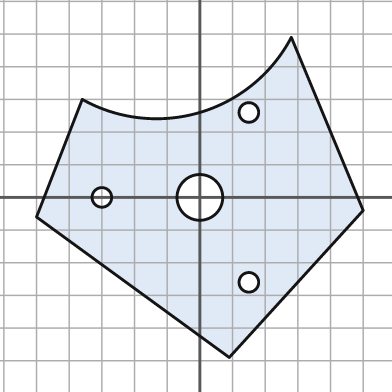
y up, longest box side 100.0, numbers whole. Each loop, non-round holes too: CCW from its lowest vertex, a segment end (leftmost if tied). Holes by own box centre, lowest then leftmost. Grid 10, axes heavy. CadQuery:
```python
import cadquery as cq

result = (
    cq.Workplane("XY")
    .moveTo(9.0, -49.0)
    .lineTo(50.0, -4.0)
    .lineTo(28.0, 49.0)
    .threePointArc((0.0, 26.0), (-36.0, 30.0))
    .lineTo(-50.0, -6.0)
    .close()
    .moveTo(15.0, -26.0)
    .circle(3.0)
    .moveTo(-30.0, 0.0)
    .circle(3.0)
    .moveTo(0.0, 0.0)
    .circle(7.0)
    .moveTo(15.0, 26.0)
    .circle(3.0)
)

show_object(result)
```